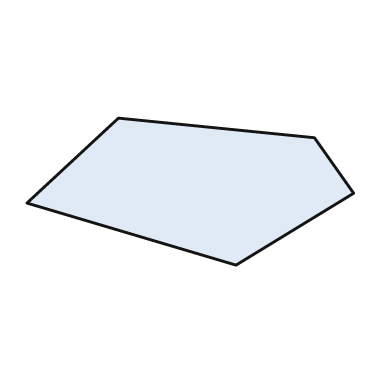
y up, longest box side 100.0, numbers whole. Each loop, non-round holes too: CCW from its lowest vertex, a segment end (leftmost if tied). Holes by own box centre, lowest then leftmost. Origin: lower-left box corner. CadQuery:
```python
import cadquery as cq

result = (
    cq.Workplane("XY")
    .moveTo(64.0, 0.0)
    .lineTo(100.0, 22.0)
    .lineTo(88.0, 39.0)
    .lineTo(28.0, 45.0)
    .lineTo(0.0, 19.0)
    .close()
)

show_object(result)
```